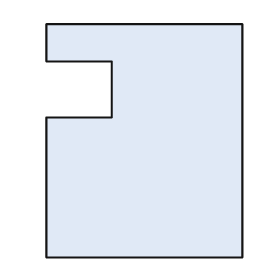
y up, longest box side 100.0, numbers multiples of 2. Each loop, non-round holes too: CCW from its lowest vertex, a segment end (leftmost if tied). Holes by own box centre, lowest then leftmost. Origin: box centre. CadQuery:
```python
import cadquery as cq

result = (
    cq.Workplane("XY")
    .moveTo(-42.0, -50.0)
    .lineTo(42.0, -50.0)
    .lineTo(42.0, 50.0)
    .lineTo(-42.0, 50.0)
    .lineTo(-42.0, 34.0)
    .lineTo(-14.0, 34.0)
    .lineTo(-14.0, 10.0)
    .lineTo(-42.0, 10.0)
    .close()
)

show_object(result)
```